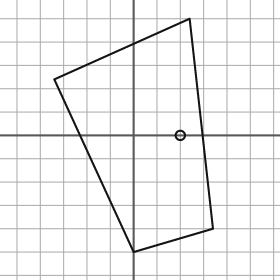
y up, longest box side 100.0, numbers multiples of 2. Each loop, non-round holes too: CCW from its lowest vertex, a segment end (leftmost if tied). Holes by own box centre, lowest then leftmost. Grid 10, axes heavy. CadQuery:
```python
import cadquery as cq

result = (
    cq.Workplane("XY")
    .moveTo(0.0, -50.0)
    .lineTo(34.0, -40.0)
    .lineTo(24.0, 50.0)
    .lineTo(-34.0, 24.0)
    .close()
    .moveTo(20.0, 0.0)
    .circle(2.0)
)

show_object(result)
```